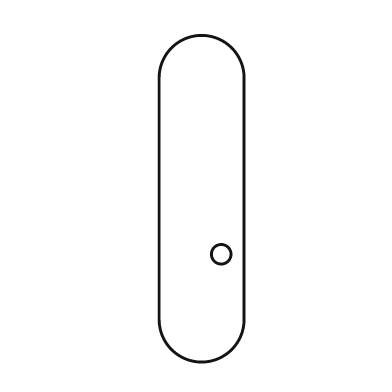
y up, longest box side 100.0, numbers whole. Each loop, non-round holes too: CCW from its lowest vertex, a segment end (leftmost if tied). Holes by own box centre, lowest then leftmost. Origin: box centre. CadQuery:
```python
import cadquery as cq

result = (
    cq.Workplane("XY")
    .moveTo(-13.0, -37.0)
    .threePointArc((0.0, -50.0), (13.0, -37.0))
    .lineTo(13.0, 37.0)
    .threePointArc((0.0, 50.0), (-13.0, 37.0))
    .close()
    .moveTo(6.0, -17.0)
    .circle(3.0)
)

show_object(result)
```